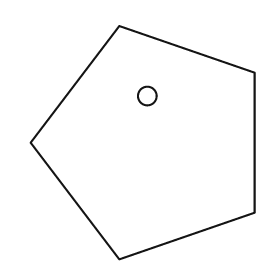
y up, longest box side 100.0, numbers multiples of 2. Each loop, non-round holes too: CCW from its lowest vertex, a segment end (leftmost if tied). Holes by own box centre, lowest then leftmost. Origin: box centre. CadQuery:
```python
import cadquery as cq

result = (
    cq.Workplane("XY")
    .moveTo(-10.0, -50.0)
    .lineTo(48.0, -30.0)
    .lineTo(48.0, 30.0)
    .lineTo(-10.0, 50.0)
    .lineTo(-48.0, 0.0)
    .close()
    .moveTo(2.0, 20.0)
    .circle(4.0)
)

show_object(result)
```